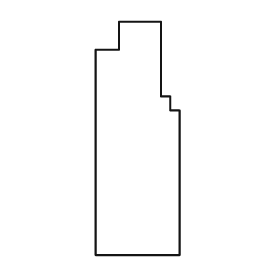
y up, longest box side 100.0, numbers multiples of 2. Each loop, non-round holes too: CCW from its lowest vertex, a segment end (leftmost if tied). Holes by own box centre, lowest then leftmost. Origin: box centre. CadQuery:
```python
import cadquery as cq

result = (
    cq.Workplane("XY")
    .moveTo(-18.0, -50.0)
    .lineTo(18.0, -50.0)
    .lineTo(18.0, 12.0)
    .lineTo(14.0, 12.0)
    .lineTo(14.0, 18.0)
    .lineTo(10.0, 18.0)
    .lineTo(10.0, 50.0)
    .lineTo(-8.0, 50.0)
    .lineTo(-8.0, 38.0)
    .lineTo(-18.0, 38.0)
    .close()
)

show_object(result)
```